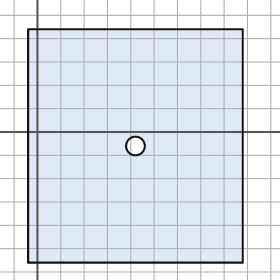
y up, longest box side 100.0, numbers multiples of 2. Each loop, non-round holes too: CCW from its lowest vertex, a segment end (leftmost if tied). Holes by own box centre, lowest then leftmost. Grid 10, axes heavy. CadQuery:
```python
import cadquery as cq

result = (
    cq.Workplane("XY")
    .moveTo(-4.0, -56.0)
    .lineTo(88.0, -56.0)
    .lineTo(88.0, 44.0)
    .lineTo(-4.0, 44.0)
    .close()
    .moveTo(42.0, -6.0)
    .circle(4.0)
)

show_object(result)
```